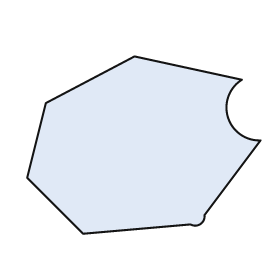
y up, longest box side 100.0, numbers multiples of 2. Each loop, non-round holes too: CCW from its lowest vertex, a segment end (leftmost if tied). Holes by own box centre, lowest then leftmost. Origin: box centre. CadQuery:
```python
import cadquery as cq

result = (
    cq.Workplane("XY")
    .moveTo(-26.0, -38.0)
    .lineTo(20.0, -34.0)
    .threePointArc((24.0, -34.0), (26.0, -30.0))
    .lineTo(50.0, 2.0)
    .threePointArc((36.0, 12.0), (42.0, 28.0))
    .lineTo(-4.0, 38.0)
    .lineTo(-42.0, 18.0)
    .lineTo(-50.0, -14.0)
    .close()
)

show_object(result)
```